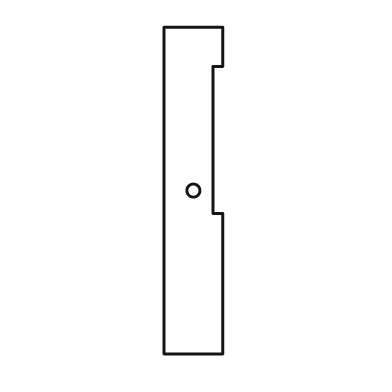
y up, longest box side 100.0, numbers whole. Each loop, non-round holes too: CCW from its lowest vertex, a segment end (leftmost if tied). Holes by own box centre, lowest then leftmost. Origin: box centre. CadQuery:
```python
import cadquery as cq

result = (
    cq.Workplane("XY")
    .moveTo(-9.0, -50.0)
    .lineTo(9.0, -50.0)
    .lineTo(9.0, -7.0)
    .lineTo(6.0, -7.0)
    .lineTo(6.0, 38.0)
    .lineTo(9.0, 38.0)
    .lineTo(9.0, 50.0)
    .lineTo(-9.0, 50.0)
    .close()
    .moveTo(0.0, 0.0)
    .circle(2.0)
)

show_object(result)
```